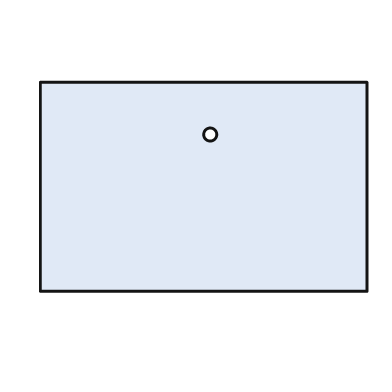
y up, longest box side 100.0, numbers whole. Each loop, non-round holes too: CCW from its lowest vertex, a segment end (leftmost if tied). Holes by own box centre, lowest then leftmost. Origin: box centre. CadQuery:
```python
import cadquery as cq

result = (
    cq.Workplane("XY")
    .moveTo(-50.0, -32.0)
    .lineTo(50.0, -32.0)
    .lineTo(50.0, 32.0)
    .lineTo(-50.0, 32.0)
    .close()
    .moveTo(2.0, 16.0)
    .circle(2.0)
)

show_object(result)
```